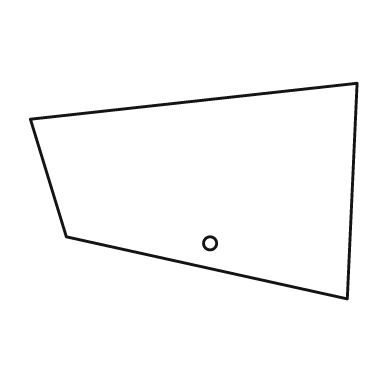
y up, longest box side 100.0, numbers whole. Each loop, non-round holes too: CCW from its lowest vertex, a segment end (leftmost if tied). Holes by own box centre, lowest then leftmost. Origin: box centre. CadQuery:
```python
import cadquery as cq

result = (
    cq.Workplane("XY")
    .moveTo(47.0, -33.0)
    .lineTo(50.0, 33.0)
    .lineTo(-50.0, 22.0)
    .lineTo(-39.0, -14.0)
    .close()
    .moveTo(5.0, -16.0)
    .circle(2.0)
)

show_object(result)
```